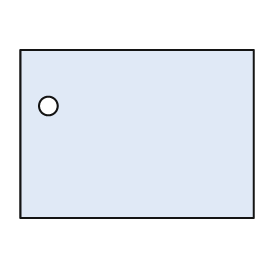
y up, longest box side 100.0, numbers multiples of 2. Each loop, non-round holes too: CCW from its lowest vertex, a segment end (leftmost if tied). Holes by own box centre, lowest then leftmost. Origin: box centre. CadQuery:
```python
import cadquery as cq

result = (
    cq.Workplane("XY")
    .moveTo(-50.0, -36.0)
    .lineTo(50.0, -36.0)
    .lineTo(50.0, 36.0)
    .lineTo(-50.0, 36.0)
    .close()
    .moveTo(-38.0, 12.0)
    .circle(4.0)
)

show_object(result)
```